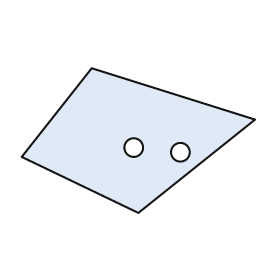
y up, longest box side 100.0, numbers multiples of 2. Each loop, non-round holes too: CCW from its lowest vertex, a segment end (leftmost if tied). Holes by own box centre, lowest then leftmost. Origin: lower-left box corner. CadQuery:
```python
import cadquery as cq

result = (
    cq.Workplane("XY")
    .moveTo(50.0, 0.0)
    .lineTo(100.0, 40.0)
    .lineTo(30.0, 62.0)
    .lineTo(0.0, 24.0)
    .close()
    .moveTo(68.0, 26.0)
    .circle(4.0)
    .moveTo(48.0, 28.0)
    .circle(4.0)
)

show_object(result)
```